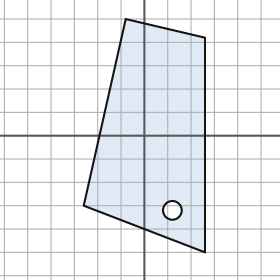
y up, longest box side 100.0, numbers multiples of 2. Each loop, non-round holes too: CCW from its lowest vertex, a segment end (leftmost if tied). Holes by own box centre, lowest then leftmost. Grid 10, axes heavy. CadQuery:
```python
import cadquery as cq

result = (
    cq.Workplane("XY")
    .moveTo(26.0, -50.0)
    .lineTo(26.0, 42.0)
    .lineTo(-8.0, 50.0)
    .lineTo(-26.0, -30.0)
    .close()
    .moveTo(12.0, -32.0)
    .circle(4.0)
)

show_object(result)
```